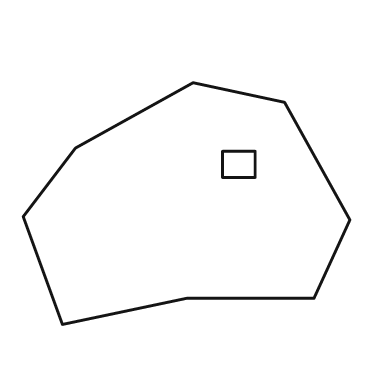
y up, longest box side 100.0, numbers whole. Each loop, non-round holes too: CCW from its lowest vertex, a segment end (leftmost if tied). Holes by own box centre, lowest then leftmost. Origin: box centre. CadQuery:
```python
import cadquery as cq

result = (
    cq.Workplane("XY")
    .moveTo(-38.0, -37.0)
    .lineTo(0.0, -29.0)
    .lineTo(39.0, -29.0)
    .lineTo(50.0, -5.0)
    .lineTo(30.0, 31.0)
    .lineTo(2.0, 37.0)
    .lineTo(-34.0, 17.0)
    .lineTo(-50.0, -4.0)
    .close()
    .moveTo(11.0, 8.0)
    .lineTo(21.0, 8.0)
    .lineTo(21.0, 16.0)
    .lineTo(11.0, 16.0)
    .close()
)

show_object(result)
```